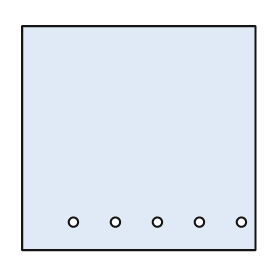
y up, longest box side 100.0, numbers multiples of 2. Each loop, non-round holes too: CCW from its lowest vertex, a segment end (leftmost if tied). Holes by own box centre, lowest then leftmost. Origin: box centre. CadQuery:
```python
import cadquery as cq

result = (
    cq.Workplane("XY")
    .moveTo(-50.0, -48.0)
    .lineTo(50.0, -48.0)
    .lineTo(50.0, 48.0)
    .lineTo(-50.0, 48.0)
    .close()
    .moveTo(-28.0, -36.0)
    .circle(2.0)
    .moveTo(-10.0, -36.0)
    .circle(2.0)
    .moveTo(8.0, -36.0)
    .circle(2.0)
    .moveTo(26.0, -36.0)
    .circle(2.0)
    .moveTo(44.0, -36.0)
    .circle(2.0)
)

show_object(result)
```